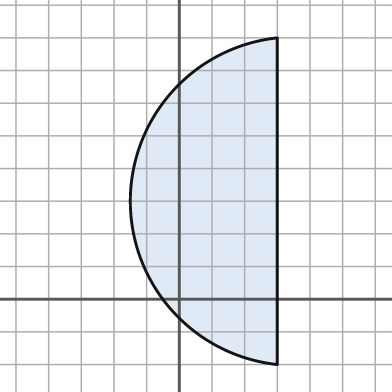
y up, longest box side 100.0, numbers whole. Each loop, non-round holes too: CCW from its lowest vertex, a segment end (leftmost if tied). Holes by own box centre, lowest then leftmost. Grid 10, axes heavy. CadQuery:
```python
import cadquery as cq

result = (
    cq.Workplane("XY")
    .moveTo(30.0, -20.0)
    .lineTo(30.0, 80.0)
    .threePointArc((-15.0, 30.0), (30.0, -20.0))
    .close()
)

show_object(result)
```